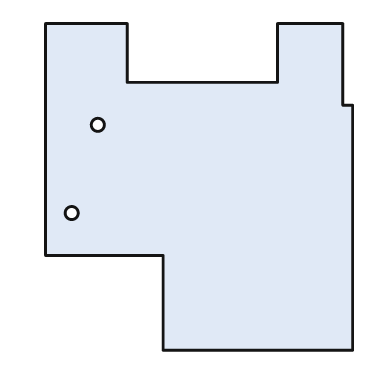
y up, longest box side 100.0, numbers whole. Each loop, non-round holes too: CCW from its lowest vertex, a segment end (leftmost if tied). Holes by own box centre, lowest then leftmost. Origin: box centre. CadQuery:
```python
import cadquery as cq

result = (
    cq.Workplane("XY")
    .moveTo(-11.0, -50.0)
    .lineTo(47.0, -50.0)
    .lineTo(47.0, 25.0)
    .lineTo(44.0, 25.0)
    .lineTo(44.0, 50.0)
    .lineTo(24.0, 50.0)
    .lineTo(24.0, 32.0)
    .lineTo(-22.0, 32.0)
    .lineTo(-22.0, 50.0)
    .lineTo(-47.0, 50.0)
    .lineTo(-47.0, -21.0)
    .lineTo(-11.0, -21.0)
    .close()
    .moveTo(-39.0, -8.0)
    .circle(2.0)
    .moveTo(-31.0, 19.0)
    .circle(2.0)
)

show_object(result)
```